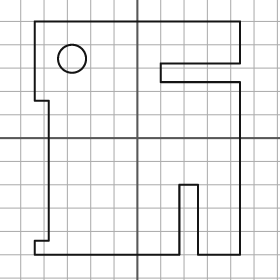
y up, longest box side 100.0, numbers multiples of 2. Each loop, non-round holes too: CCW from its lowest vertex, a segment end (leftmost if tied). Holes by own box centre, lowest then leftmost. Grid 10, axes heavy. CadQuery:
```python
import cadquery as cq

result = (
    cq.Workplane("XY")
    .moveTo(-44.0, -50.0)
    .lineTo(18.0, -50.0)
    .lineTo(18.0, -20.0)
    .lineTo(26.0, -20.0)
    .lineTo(26.0, -50.0)
    .lineTo(44.0, -50.0)
    .lineTo(44.0, 24.0)
    .lineTo(10.0, 24.0)
    .lineTo(10.0, 32.0)
    .lineTo(44.0, 32.0)
    .lineTo(44.0, 50.0)
    .lineTo(-44.0, 50.0)
    .lineTo(-44.0, 16.0)
    .lineTo(-38.0, 16.0)
    .lineTo(-38.0, -44.0)
    .lineTo(-44.0, -44.0)
    .close()
    .moveTo(-28.0, 34.0)
    .circle(6.0)
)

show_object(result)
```